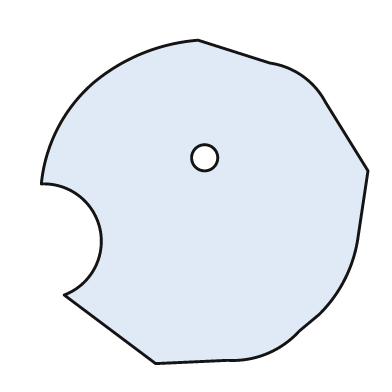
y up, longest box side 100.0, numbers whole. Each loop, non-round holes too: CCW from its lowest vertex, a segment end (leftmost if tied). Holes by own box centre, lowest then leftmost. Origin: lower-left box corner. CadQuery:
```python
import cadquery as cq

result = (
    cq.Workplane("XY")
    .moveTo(35.0, 0.0)
    .lineTo(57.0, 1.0)
    .threePointArc((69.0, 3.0), (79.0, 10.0))
    .lineTo(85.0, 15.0)
    .threePointArc((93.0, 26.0), (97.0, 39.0))
    .lineTo(100.0, 59.0)
    .lineTo(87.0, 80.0)
    .threePointArc((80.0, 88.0), (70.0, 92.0))
    .lineTo(48.0, 99.0)
    .threePointArc((31.0, 95.0), (16.0, 86.0))
    .threePointArc((5.0, 72.0), (0.0, 55.0))
    .threePointArc((18.0, 41.0), (7.0, 21.0))
    .close()
    .moveTo(50.0, 63.0)
    .circle(4.0)
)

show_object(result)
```